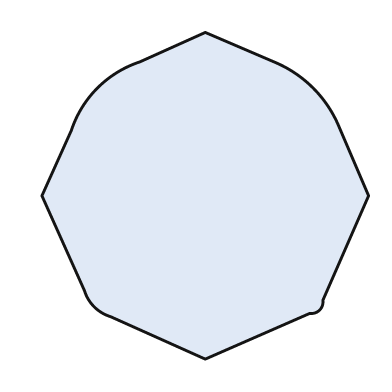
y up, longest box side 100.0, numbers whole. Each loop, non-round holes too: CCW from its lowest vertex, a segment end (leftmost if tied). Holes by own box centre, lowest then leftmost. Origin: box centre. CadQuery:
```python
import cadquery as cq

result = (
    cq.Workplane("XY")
    .moveTo(0.0, -50.0)
    .lineTo(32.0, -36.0)
    .threePointArc((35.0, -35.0), (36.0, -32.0))
    .lineTo(50.0, 0.0)
    .lineTo(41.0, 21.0)
    .threePointArc((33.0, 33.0), (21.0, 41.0))
    .lineTo(0.0, 50.0)
    .lineTo(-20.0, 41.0)
    .threePointArc((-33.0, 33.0), (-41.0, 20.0))
    .lineTo(-50.0, 0.0)
    .lineTo(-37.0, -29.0)
    .threePointArc((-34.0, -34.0), (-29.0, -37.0))
    .close()
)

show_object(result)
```